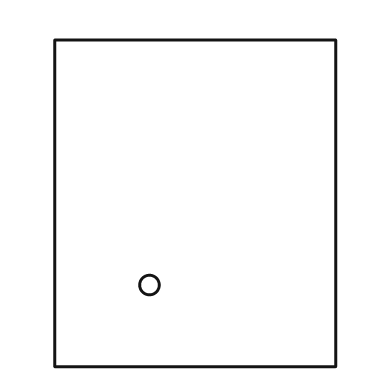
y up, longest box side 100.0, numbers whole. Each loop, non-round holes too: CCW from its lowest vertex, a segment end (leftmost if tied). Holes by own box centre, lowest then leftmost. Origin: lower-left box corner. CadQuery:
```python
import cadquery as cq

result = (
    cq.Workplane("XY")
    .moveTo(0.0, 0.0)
    .lineTo(86.0, 0.0)
    .lineTo(86.0, 100.0)
    .lineTo(0.0, 100.0)
    .close()
    .moveTo(29.0, 25.0)
    .circle(3.0)
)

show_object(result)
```